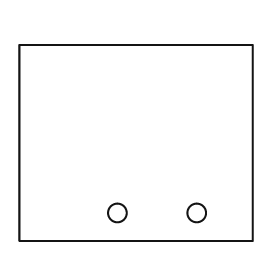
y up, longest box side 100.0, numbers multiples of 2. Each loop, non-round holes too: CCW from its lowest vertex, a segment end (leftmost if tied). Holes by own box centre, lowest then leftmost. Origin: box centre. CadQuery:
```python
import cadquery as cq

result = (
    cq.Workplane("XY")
    .moveTo(-50.0, -42.0)
    .lineTo(50.0, -42.0)
    .lineTo(50.0, 42.0)
    .lineTo(-50.0, 42.0)
    .close()
    .moveTo(-8.0, -30.0)
    .circle(4.0)
    .moveTo(26.0, -30.0)
    .circle(4.0)
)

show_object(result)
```